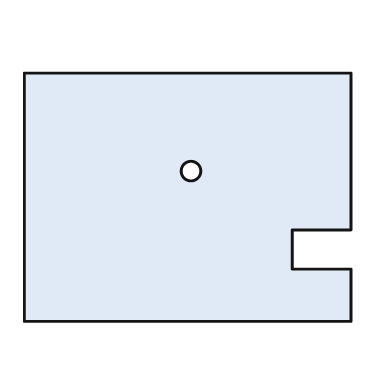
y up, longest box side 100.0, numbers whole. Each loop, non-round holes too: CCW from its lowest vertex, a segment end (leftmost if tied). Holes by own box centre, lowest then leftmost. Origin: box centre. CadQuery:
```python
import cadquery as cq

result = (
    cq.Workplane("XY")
    .moveTo(-50.0, -38.0)
    .lineTo(50.0, -38.0)
    .lineTo(50.0, -22.0)
    .lineTo(32.0, -22.0)
    .lineTo(32.0, -10.0)
    .lineTo(50.0, -10.0)
    .lineTo(50.0, 38.0)
    .lineTo(-50.0, 38.0)
    .close()
    .moveTo(1.0, 8.0)
    .circle(3.0)
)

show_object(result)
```